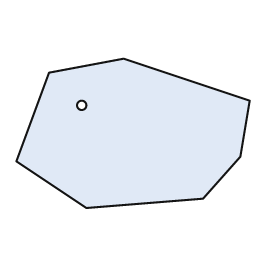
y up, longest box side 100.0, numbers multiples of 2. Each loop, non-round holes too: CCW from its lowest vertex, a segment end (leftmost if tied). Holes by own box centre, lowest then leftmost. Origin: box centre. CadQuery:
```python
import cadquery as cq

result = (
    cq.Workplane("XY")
    .moveTo(-20.0, -32.0)
    .lineTo(30.0, -28.0)
    .lineTo(46.0, -10.0)
    .lineTo(50.0, 14.0)
    .lineTo(-4.0, 32.0)
    .lineTo(-36.0, 26.0)
    .lineTo(-50.0, -12.0)
    .close()
    .moveTo(-22.0, 12.0)
    .circle(2.0)
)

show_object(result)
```